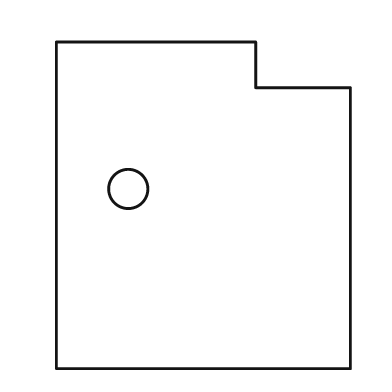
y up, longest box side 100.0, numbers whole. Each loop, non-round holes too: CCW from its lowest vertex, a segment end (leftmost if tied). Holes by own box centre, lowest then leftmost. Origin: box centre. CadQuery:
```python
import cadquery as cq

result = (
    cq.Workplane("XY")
    .moveTo(-45.0, -50.0)
    .lineTo(45.0, -50.0)
    .lineTo(45.0, 36.0)
    .lineTo(16.0, 36.0)
    .lineTo(16.0, 50.0)
    .lineTo(-45.0, 50.0)
    .close()
    .moveTo(-23.0, 5.0)
    .circle(6.0)
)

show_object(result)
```